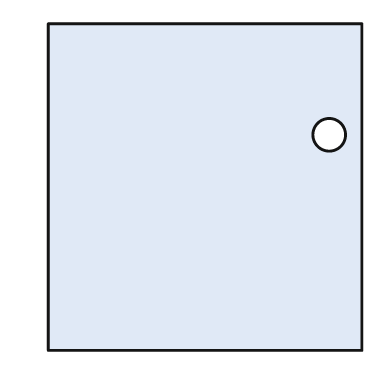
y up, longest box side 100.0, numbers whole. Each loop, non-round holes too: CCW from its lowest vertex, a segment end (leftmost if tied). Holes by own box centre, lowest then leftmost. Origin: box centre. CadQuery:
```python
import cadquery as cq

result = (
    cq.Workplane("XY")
    .moveTo(-48.0, -50.0)
    .lineTo(48.0, -50.0)
    .lineTo(48.0, 50.0)
    .lineTo(-48.0, 50.0)
    .close()
    .moveTo(38.0, 16.0)
    .circle(5.0)
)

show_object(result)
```